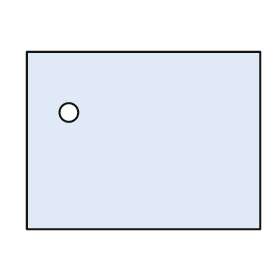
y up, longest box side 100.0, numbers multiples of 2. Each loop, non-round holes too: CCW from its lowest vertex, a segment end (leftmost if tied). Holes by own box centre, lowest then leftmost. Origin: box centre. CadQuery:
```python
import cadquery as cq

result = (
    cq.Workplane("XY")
    .moveTo(-50.0, -38.0)
    .lineTo(50.0, -38.0)
    .lineTo(50.0, 38.0)
    .lineTo(-50.0, 38.0)
    .close()
    .moveTo(-32.0, 12.0)
    .circle(4.0)
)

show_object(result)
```